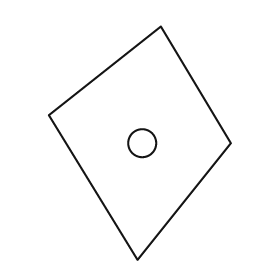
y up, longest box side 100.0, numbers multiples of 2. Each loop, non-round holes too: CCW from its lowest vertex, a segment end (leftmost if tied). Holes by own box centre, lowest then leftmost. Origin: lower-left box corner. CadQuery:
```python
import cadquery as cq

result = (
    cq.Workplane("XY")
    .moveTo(38.0, 0.0)
    .lineTo(78.0, 50.0)
    .lineTo(48.0, 100.0)
    .lineTo(0.0, 62.0)
    .close()
    .moveTo(40.0, 50.0)
    .circle(6.0)
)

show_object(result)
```